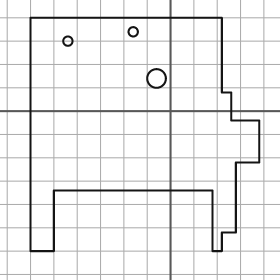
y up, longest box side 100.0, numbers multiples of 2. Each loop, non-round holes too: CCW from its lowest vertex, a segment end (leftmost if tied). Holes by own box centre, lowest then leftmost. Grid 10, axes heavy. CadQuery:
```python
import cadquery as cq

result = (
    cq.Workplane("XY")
    .moveTo(-60.0, -60.0)
    .lineTo(-50.0, -60.0)
    .lineTo(-50.0, -34.0)
    .lineTo(18.0, -34.0)
    .lineTo(18.0, -60.0)
    .lineTo(22.0, -60.0)
    .lineTo(22.0, -52.0)
    .lineTo(28.0, -52.0)
    .lineTo(28.0, -22.0)
    .lineTo(38.0, -22.0)
    .lineTo(38.0, -4.0)
    .lineTo(26.0, -4.0)
    .lineTo(26.0, 8.0)
    .lineTo(22.0, 8.0)
    .lineTo(22.0, 40.0)
    .lineTo(-60.0, 40.0)
    .close()
    .moveTo(-6.0, 14.0)
    .circle(4.0)
    .moveTo(-44.0, 30.0)
    .circle(2.0)
    .moveTo(-16.0, 34.0)
    .circle(2.0)
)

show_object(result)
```